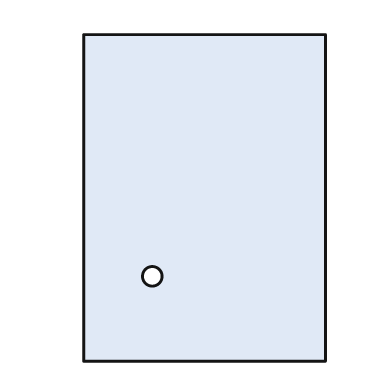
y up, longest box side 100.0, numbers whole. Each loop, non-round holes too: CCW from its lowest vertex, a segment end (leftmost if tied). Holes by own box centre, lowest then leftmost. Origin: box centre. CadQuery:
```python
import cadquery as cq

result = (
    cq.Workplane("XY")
    .moveTo(-37.0, -50.0)
    .lineTo(37.0, -50.0)
    .lineTo(37.0, 50.0)
    .lineTo(-37.0, 50.0)
    .close()
    .moveTo(-16.0, -24.0)
    .circle(3.0)
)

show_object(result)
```